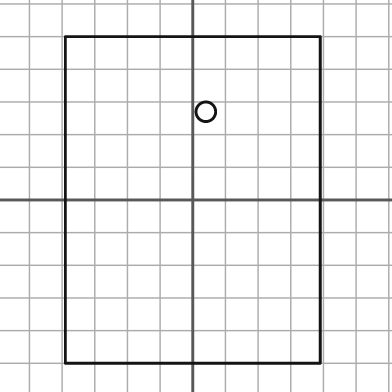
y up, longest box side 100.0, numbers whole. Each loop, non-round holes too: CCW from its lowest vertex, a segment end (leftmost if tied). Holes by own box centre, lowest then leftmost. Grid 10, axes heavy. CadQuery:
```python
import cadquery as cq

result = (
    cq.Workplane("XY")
    .moveTo(-39.0, -50.0)
    .lineTo(39.0, -50.0)
    .lineTo(39.0, 50.0)
    .lineTo(-39.0, 50.0)
    .close()
    .moveTo(4.0, 27.0)
    .circle(3.0)
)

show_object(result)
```